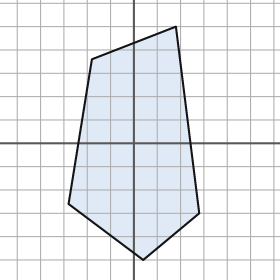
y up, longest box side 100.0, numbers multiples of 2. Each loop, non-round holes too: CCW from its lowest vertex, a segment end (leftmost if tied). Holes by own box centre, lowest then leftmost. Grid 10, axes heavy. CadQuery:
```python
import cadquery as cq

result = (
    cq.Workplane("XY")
    .moveTo(4.0, -50.0)
    .lineTo(28.0, -30.0)
    .lineTo(18.0, 50.0)
    .lineTo(-18.0, 36.0)
    .lineTo(-28.0, -26.0)
    .close()
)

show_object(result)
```